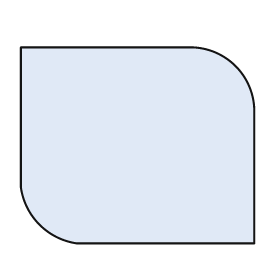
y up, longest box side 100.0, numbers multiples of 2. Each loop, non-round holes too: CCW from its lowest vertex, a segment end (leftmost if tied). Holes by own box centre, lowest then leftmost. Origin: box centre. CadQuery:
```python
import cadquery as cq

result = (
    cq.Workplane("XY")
    .moveTo(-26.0, -42.0)
    .lineTo(50.0, -42.0)
    .lineTo(50.0, 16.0)
    .threePointArc((42.0, 34.0), (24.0, 42.0))
    .lineTo(-50.0, 42.0)
    .lineTo(-50.0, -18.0)
    .threePointArc((-42.0, -34.0), (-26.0, -42.0))
    .close()
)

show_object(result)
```